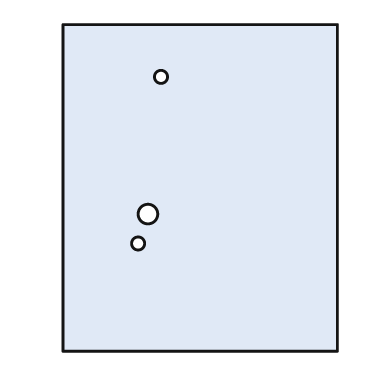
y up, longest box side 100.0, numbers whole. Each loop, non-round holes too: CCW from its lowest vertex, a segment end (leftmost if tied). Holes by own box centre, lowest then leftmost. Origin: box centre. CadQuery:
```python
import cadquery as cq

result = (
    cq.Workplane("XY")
    .moveTo(-42.0, -50.0)
    .lineTo(42.0, -50.0)
    .lineTo(42.0, 50.0)
    .lineTo(-42.0, 50.0)
    .close()
    .moveTo(-19.0, -17.0)
    .circle(2.0)
    .moveTo(-16.0, -8.0)
    .circle(3.0)
    .moveTo(-12.0, 34.0)
    .circle(2.0)
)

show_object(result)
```